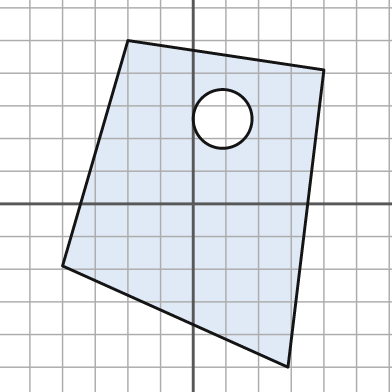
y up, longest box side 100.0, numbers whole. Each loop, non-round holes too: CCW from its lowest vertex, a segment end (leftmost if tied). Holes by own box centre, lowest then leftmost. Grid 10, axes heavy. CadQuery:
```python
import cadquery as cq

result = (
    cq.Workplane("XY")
    .moveTo(29.0, -50.0)
    .lineTo(40.0, 41.0)
    .lineTo(-20.0, 50.0)
    .lineTo(-40.0, -19.0)
    .close()
    .moveTo(9.0, 26.0)
    .circle(9.0)
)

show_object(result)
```